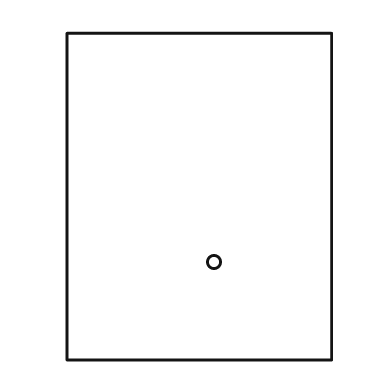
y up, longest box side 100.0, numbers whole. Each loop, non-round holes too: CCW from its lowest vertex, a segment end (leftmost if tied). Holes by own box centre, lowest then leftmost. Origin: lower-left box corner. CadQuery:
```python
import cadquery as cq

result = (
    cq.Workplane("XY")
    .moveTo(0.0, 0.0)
    .lineTo(81.0, 0.0)
    .lineTo(81.0, 100.0)
    .lineTo(0.0, 100.0)
    .close()
    .moveTo(45.0, 30.0)
    .circle(2.0)
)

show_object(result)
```